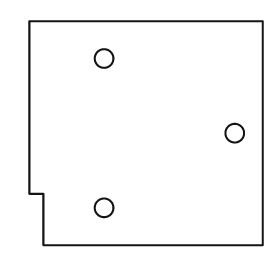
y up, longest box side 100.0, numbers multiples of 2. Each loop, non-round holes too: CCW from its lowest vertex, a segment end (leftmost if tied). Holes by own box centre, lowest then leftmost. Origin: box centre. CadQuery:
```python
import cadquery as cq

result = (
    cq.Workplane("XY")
    .moveTo(-44.0, -48.0)
    .lineTo(50.0, -48.0)
    .lineTo(50.0, 48.0)
    .lineTo(-50.0, 48.0)
    .lineTo(-50.0, -26.0)
    .lineTo(-44.0, -26.0)
    .close()
    .moveTo(-18.0, -32.0)
    .circle(4.0)
    .moveTo(38.0, 0.0)
    .circle(4.0)
    .moveTo(-18.0, 32.0)
    .circle(4.0)
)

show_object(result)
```